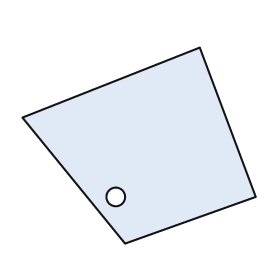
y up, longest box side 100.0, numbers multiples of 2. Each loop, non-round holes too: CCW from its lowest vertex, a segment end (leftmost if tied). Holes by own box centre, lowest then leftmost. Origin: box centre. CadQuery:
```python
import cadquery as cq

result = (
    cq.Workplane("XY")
    .moveTo(-6.0, -42.0)
    .lineTo(50.0, -22.0)
    .lineTo(26.0, 42.0)
    .lineTo(-50.0, 12.0)
    .close()
    .moveTo(-10.0, -22.0)
    .circle(4.0)
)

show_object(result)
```